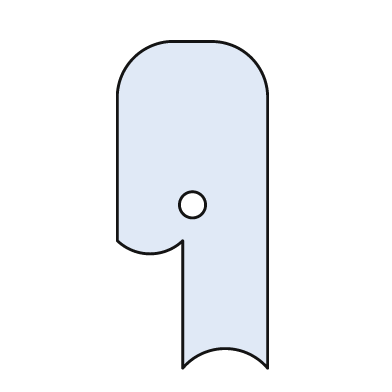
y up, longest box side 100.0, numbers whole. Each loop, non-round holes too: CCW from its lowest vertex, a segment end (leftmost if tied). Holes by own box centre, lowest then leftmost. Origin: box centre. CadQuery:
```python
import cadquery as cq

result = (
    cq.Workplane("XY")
    .moveTo(-3.0, -50.0)
    .threePointArc((10.0, -44.0), (23.0, -50.0))
    .lineTo(23.0, 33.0)
    .threePointArc((18.0, 45.0), (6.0, 50.0))
    .lineTo(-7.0, 50.0)
    .threePointArc((-18.0, 45.0), (-23.0, 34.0))
    .lineTo(-23.0, -11.0)
    .threePointArc((-13.0, -15.0), (-3.0, -11.0))
    .close()
    .moveTo(0.0, 0.0)
    .circle(4.0)
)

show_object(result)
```